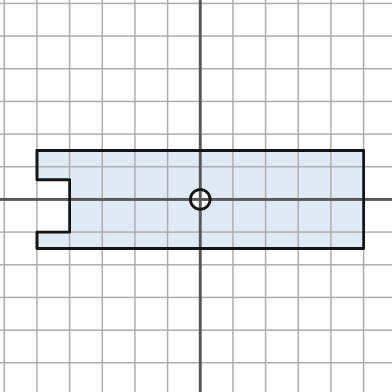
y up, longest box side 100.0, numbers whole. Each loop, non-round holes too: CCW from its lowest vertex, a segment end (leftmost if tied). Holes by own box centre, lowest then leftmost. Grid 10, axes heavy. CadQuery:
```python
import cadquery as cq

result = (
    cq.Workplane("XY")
    .moveTo(-50.0, -15.0)
    .lineTo(50.0, -15.0)
    .lineTo(50.0, 15.0)
    .lineTo(-50.0, 15.0)
    .lineTo(-50.0, 6.0)
    .lineTo(-40.0, 6.0)
    .lineTo(-40.0, -10.0)
    .lineTo(-50.0, -10.0)
    .close()
    .moveTo(0.0, 0.0)
    .circle(3.0)
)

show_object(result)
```